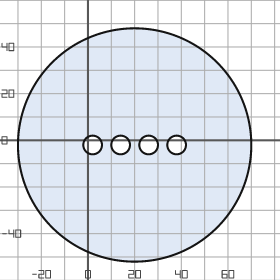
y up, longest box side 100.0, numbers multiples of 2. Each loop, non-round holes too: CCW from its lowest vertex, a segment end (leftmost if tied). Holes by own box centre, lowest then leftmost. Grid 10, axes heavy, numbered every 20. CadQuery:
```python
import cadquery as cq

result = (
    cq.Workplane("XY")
    .moveTo(20.0, -2.0)
    .circle(50.0)
    .moveTo(2.0, -2.0)
    .circle(4.0)
    .moveTo(14.0, -2.0)
    .circle(4.0)
    .moveTo(26.0, -2.0)
    .circle(4.0)
    .moveTo(38.0, -2.0)
    .circle(4.0)
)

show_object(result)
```